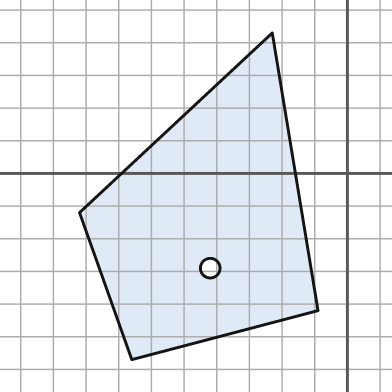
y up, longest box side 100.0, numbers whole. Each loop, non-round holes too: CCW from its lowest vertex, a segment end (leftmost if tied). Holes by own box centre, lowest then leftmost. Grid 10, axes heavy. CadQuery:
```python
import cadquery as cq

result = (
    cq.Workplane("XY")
    .moveTo(-66.0, -57.0)
    .lineTo(-9.0, -42.0)
    .lineTo(-23.0, 43.0)
    .lineTo(-82.0, -12.0)
    .close()
    .moveTo(-42.0, -29.0)
    .circle(3.0)
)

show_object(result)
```